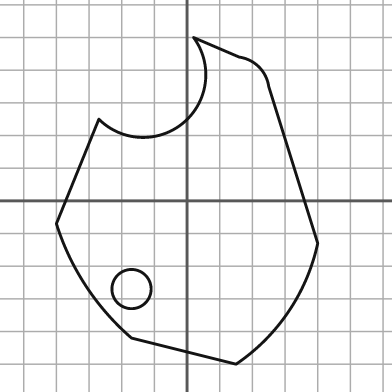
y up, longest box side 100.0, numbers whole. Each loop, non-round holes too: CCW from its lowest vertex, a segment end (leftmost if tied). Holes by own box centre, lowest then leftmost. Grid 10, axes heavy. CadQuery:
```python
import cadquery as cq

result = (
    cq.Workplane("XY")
    .moveTo(15.0, -50.0)
    .threePointArc((31.0, -34.0), (40.0, -13.0))
    .lineTo(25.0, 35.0)
    .threePointArc((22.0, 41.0), (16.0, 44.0))
    .lineTo(2.0, 50.0)
    .threePointArc((-1.0, 24.0), (-27.0, 25.0))
    .lineTo(-40.0, -7.0)
    .threePointArc((-31.0, -26.0), (-17.0, -42.0))
    .close()
    .moveTo(-17.0, -27.0)
    .circle(6.0)
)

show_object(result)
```